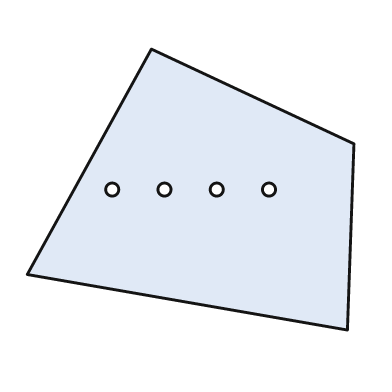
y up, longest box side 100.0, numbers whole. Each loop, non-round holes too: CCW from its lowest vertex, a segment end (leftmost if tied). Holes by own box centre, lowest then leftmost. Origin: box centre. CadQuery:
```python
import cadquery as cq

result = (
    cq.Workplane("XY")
    .moveTo(48.0, -43.0)
    .lineTo(50.0, 14.0)
    .lineTo(-12.0, 43.0)
    .lineTo(-50.0, -26.0)
    .close()
    .moveTo(-24.0, 0.0)
    .circle(2.0)
    .moveTo(-8.0, 0.0)
    .circle(2.0)
    .moveTo(8.0, 0.0)
    .circle(2.0)
    .moveTo(24.0, 0.0)
    .circle(2.0)
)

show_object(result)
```